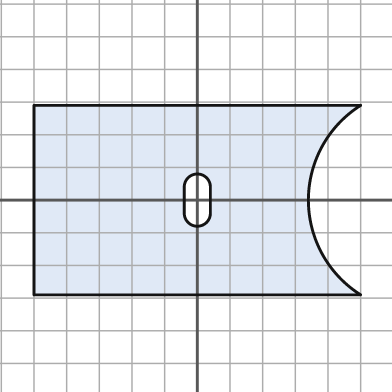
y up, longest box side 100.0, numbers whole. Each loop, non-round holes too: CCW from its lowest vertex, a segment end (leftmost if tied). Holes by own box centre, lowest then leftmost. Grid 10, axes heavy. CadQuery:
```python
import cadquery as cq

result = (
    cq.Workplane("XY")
    .moveTo(-50.0, -29.0)
    .lineTo(50.0, -29.0)
    .threePointArc((34.0, 0.0), (50.0, 29.0))
    .lineTo(-50.0, 29.0)
    .close()
    .moveTo(-4.0, -4.0)
    .threePointArc((0.0, -8.0), (4.0, -4.0))
    .lineTo(4.0, 4.0)
    .threePointArc((0.0, 8.0), (-4.0, 4.0))
    .close()
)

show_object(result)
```